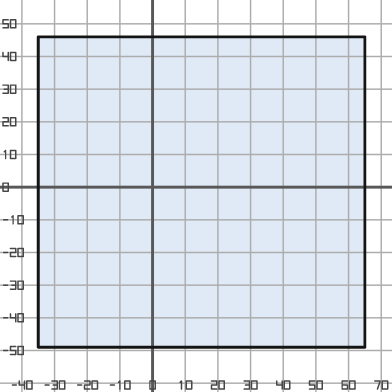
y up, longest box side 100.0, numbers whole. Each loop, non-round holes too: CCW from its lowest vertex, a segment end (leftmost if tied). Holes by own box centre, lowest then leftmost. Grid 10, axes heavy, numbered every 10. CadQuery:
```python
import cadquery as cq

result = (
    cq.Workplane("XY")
    .moveTo(-35.0, -49.0)
    .lineTo(65.0, -49.0)
    .lineTo(65.0, 46.0)
    .lineTo(-35.0, 46.0)
    .close()
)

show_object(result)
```